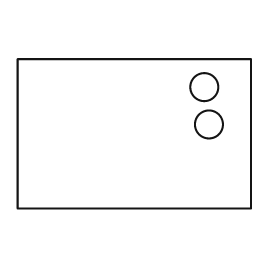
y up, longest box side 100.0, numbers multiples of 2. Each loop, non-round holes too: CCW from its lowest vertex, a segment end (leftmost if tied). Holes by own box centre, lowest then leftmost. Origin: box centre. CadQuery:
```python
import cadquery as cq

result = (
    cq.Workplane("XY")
    .moveTo(-50.0, -32.0)
    .lineTo(50.0, -32.0)
    .lineTo(50.0, 32.0)
    .lineTo(-50.0, 32.0)
    .close()
    .moveTo(32.0, 4.0)
    .circle(6.0)
    .moveTo(30.0, 20.0)
    .circle(6.0)
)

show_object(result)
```